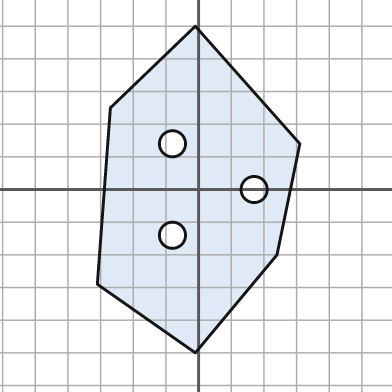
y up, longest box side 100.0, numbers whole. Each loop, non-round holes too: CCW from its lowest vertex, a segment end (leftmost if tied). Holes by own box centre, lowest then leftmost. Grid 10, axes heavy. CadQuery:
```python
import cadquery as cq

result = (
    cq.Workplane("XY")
    .moveTo(-1.0, -50.0)
    .lineTo(24.0, -20.0)
    .lineTo(31.0, 14.0)
    .lineTo(-1.0, 50.0)
    .lineTo(-27.0, 25.0)
    .lineTo(-31.0, -29.0)
    .close()
    .moveTo(-8.0, -14.0)
    .circle(4.0)
    .moveTo(17.0, 0.0)
    .circle(4.0)
    .moveTo(-8.0, 14.0)
    .circle(4.0)
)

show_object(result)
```